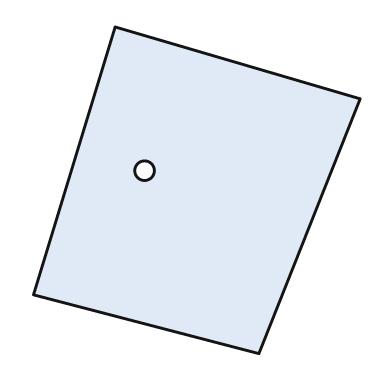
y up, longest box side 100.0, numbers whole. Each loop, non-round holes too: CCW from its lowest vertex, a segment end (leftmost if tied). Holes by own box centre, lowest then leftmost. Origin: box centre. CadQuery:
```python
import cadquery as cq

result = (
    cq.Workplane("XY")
    .moveTo(19.0, -50.0)
    .lineTo(50.0, 28.0)
    .lineTo(-25.0, 50.0)
    .lineTo(-50.0, -32.0)
    .close()
    .moveTo(-16.0, 6.0)
    .circle(3.0)
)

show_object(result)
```